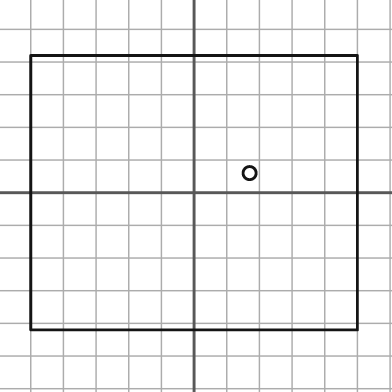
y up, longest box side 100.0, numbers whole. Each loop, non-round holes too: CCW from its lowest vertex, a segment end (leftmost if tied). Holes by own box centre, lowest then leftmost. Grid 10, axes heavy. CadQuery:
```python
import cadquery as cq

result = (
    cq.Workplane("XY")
    .moveTo(-50.0, -42.0)
    .lineTo(50.0, -42.0)
    .lineTo(50.0, 42.0)
    .lineTo(-50.0, 42.0)
    .close()
    .moveTo(17.0, 6.0)
    .circle(2.0)
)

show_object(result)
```